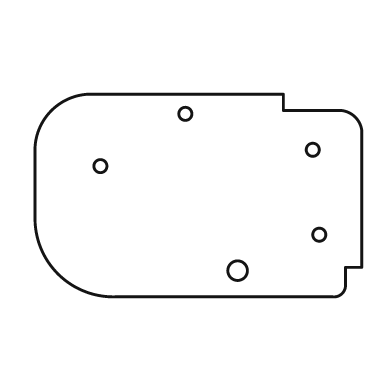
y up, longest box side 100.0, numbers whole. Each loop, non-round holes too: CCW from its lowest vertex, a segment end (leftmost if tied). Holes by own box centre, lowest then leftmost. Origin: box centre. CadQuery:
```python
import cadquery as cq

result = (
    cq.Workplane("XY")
    .moveTo(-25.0, -31.0)
    .lineTo(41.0, -31.0)
    .threePointArc((44.0, -30.0), (45.0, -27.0))
    .lineTo(45.0, -22.0)
    .lineTo(50.0, -22.0)
    .lineTo(50.0, 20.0)
    .threePointArc((48.0, 24.0), (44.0, 26.0))
    .lineTo(26.0, 26.0)
    .lineTo(26.0, 31.0)
    .lineTo(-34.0, 31.0)
    .threePointArc((-45.0, 26.0), (-50.0, 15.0))
    .lineTo(-50.0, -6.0)
    .threePointArc((-43.0, -24.0), (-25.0, -31.0))
    .close()
    .moveTo(12.0, -23.0)
    .circle(3.0)
    .moveTo(37.0, -12.0)
    .circle(2.0)
    .moveTo(-30.0, 9.0)
    .circle(2.0)
    .moveTo(35.0, 14.0)
    .circle(2.0)
    .moveTo(-4.0, 25.0)
    .circle(2.0)
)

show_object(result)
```